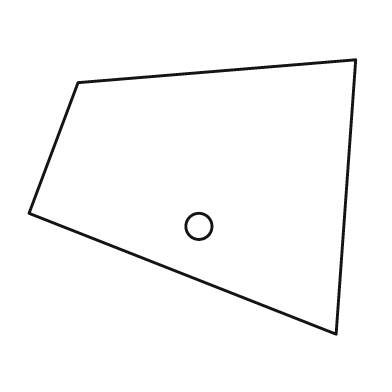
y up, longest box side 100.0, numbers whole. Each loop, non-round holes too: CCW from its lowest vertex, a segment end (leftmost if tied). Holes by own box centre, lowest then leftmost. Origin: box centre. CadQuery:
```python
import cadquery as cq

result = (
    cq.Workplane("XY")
    .moveTo(44.0, -42.0)
    .lineTo(50.0, 42.0)
    .lineTo(-35.0, 35.0)
    .lineTo(-50.0, -5.0)
    .close()
    .moveTo(2.0, -9.0)
    .circle(4.0)
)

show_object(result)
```